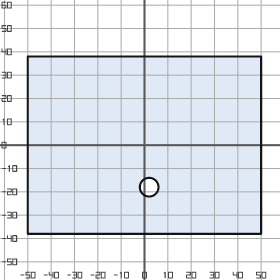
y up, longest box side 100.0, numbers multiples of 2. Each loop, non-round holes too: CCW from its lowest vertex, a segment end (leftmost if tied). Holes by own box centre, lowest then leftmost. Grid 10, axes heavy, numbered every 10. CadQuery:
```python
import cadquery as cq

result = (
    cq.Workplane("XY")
    .moveTo(-50.0, -38.0)
    .lineTo(50.0, -38.0)
    .lineTo(50.0, 38.0)
    .lineTo(-50.0, 38.0)
    .close()
    .moveTo(2.0, -18.0)
    .circle(4.0)
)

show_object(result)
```